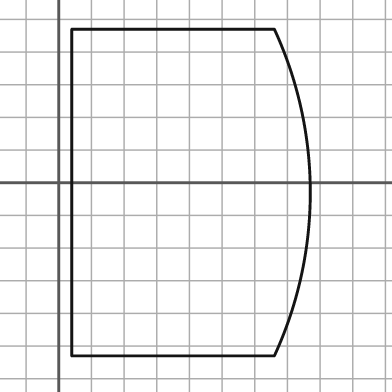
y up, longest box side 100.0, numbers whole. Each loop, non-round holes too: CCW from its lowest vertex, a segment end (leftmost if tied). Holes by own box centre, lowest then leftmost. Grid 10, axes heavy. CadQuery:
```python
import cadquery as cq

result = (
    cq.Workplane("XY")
    .moveTo(4.0, -53.0)
    .lineTo(66.0, -53.0)
    .threePointArc((77.0, -3.0), (66.0, 47.0))
    .lineTo(4.0, 47.0)
    .close()
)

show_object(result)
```